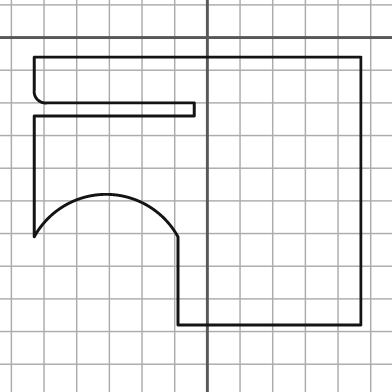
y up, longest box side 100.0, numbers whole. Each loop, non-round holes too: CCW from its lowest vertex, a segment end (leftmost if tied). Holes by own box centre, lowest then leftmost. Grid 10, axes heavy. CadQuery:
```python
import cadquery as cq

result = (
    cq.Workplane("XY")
    .moveTo(-9.0, -88.0)
    .lineTo(47.0, -88.0)
    .lineTo(47.0, -6.0)
    .lineTo(-53.0, -6.0)
    .lineTo(-53.0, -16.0)
    .threePointArc((-52.0, -19.0), (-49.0, -20.0))
    .lineTo(-4.0, -20.0)
    .lineTo(-4.0, -24.0)
    .lineTo(-53.0, -24.0)
    .lineTo(-53.0, -61.0)
    .threePointArc((-31.0, -48.0), (-9.0, -61.0))
    .close()
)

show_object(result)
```